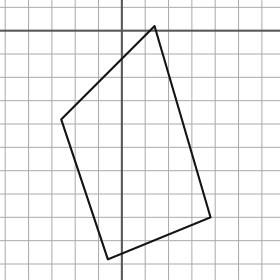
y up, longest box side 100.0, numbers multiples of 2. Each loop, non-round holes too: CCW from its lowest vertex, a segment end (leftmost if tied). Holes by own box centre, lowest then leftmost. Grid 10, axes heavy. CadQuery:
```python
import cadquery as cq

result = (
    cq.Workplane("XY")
    .moveTo(-6.0, -98.0)
    .lineTo(38.0, -80.0)
    .lineTo(14.0, 2.0)
    .lineTo(-26.0, -38.0)
    .close()
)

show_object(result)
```